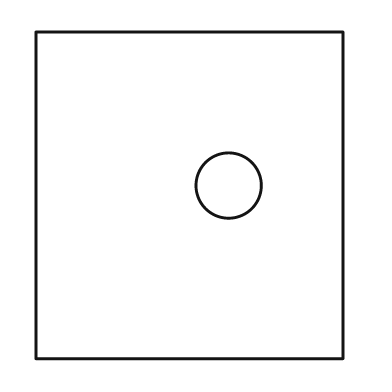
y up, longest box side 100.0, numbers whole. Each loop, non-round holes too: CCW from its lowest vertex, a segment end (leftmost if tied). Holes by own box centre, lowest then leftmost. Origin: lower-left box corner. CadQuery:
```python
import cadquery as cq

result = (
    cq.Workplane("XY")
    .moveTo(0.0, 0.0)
    .lineTo(94.0, 0.0)
    .lineTo(94.0, 100.0)
    .lineTo(0.0, 100.0)
    .close()
    .moveTo(59.0, 53.0)
    .circle(10.0)
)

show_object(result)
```